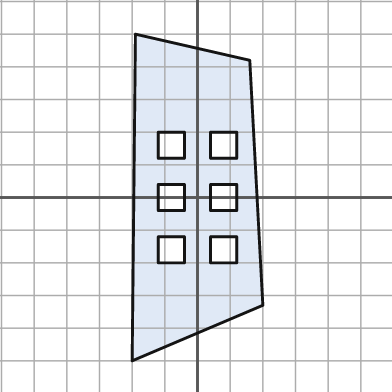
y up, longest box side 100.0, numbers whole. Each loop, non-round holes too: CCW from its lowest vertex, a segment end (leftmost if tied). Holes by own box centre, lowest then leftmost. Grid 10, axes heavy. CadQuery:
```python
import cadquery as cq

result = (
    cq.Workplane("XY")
    .moveTo(-20.0, -50.0)
    .lineTo(20.0, -33.0)
    .lineTo(16.0, 42.0)
    .lineTo(-19.0, 50.0)
    .close()
    .moveTo(-12.0, -20.0)
    .lineTo(-4.0, -20.0)
    .lineTo(-4.0, -12.0)
    .lineTo(-12.0, -12.0)
    .close()
    .moveTo(4.0, -20.0)
    .lineTo(12.0, -20.0)
    .lineTo(12.0, -12.0)
    .lineTo(4.0, -12.0)
    .close()
    .moveTo(-12.0, -4.0)
    .lineTo(-4.0, -4.0)
    .lineTo(-4.0, 4.0)
    .lineTo(-12.0, 4.0)
    .close()
    .moveTo(4.0, -4.0)
    .lineTo(12.0, -4.0)
    .lineTo(12.0, 4.0)
    .lineTo(4.0, 4.0)
    .close()
    .moveTo(-12.0, 12.0)
    .lineTo(-4.0, 12.0)
    .lineTo(-4.0, 20.0)
    .lineTo(-12.0, 20.0)
    .close()
    .moveTo(4.0, 12.0)
    .lineTo(12.0, 12.0)
    .lineTo(12.0, 20.0)
    .lineTo(4.0, 20.0)
    .close()
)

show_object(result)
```